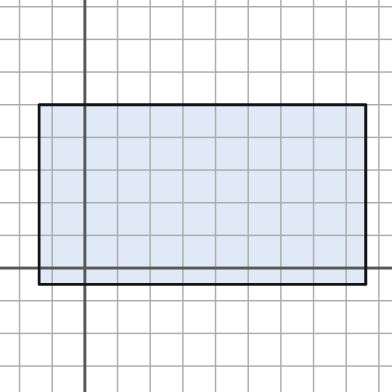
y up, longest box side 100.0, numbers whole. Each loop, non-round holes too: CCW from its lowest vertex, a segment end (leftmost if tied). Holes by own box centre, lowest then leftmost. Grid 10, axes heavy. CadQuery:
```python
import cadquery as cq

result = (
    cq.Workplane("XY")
    .moveTo(-14.0, -5.0)
    .lineTo(86.0, -5.0)
    .lineTo(86.0, 50.0)
    .lineTo(-14.0, 50.0)
    .close()
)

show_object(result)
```